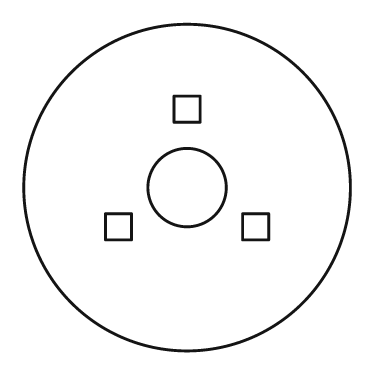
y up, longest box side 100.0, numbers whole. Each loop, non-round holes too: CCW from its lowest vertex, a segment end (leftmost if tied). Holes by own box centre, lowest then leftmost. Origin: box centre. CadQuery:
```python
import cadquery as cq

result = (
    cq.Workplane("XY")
    .moveTo(0.0, 0.0)
    .circle(50.0)
    .moveTo(-25.0, -16.0)
    .lineTo(-17.0, -16.0)
    .lineTo(-17.0, -8.0)
    .lineTo(-25.0, -8.0)
    .close()
    .moveTo(17.0, -16.0)
    .lineTo(25.0, -16.0)
    .lineTo(25.0, -8.0)
    .lineTo(17.0, -8.0)
    .close()
    .moveTo(0.0, 0.0)
    .circle(12.0)
    .moveTo(-4.0, 20.0)
    .lineTo(4.0, 20.0)
    .lineTo(4.0, 28.0)
    .lineTo(-4.0, 28.0)
    .close()
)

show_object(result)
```